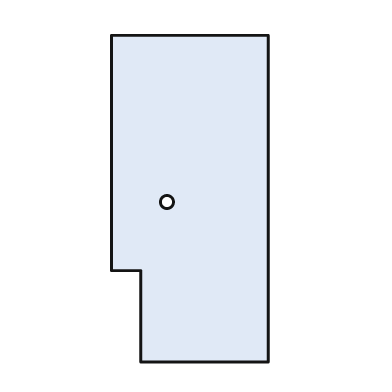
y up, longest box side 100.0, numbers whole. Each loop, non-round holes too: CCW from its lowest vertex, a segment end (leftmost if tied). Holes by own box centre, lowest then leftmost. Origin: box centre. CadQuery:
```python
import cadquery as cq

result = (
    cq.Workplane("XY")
    .moveTo(-15.0, -50.0)
    .lineTo(24.0, -50.0)
    .lineTo(24.0, 50.0)
    .lineTo(-24.0, 50.0)
    .lineTo(-24.0, -22.0)
    .lineTo(-15.0, -22.0)
    .close()
    .moveTo(-7.0, -1.0)
    .circle(2.0)
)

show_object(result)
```